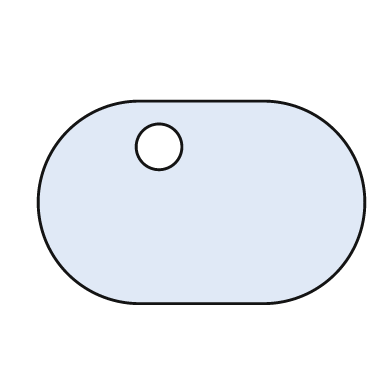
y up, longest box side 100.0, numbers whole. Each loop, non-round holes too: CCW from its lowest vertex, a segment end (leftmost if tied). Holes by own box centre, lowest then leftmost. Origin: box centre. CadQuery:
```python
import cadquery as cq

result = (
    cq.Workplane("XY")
    .moveTo(-19.0, -31.0)
    .lineTo(19.0, -31.0)
    .threePointArc((50.0, 0.0), (19.0, 31.0))
    .lineTo(-19.0, 31.0)
    .threePointArc((-50.0, 0.0), (-19.0, -31.0))
    .close()
    .moveTo(-13.0, 17.0)
    .circle(7.0)
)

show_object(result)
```